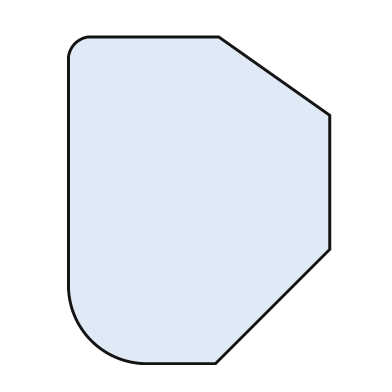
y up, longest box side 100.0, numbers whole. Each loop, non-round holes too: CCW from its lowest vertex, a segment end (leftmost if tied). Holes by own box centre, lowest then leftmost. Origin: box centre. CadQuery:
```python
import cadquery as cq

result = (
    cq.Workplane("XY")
    .moveTo(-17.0, -50.0)
    .lineTo(5.0, -50.0)
    .lineTo(40.0, -15.0)
    .lineTo(40.0, 26.0)
    .lineTo(6.0, 50.0)
    .lineTo(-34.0, 50.0)
    .threePointArc((-38.0, 48.0), (-40.0, 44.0))
    .lineTo(-40.0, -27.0)
    .threePointArc((-33.0, -43.0), (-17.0, -50.0))
    .close()
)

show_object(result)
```